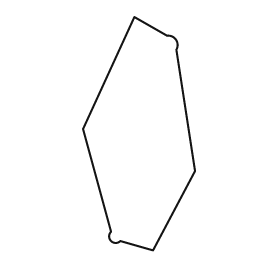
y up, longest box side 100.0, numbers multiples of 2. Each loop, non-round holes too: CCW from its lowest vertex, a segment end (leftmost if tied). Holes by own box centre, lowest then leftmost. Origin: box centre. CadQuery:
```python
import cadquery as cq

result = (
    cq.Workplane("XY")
    .moveTo(6.0, -50.0)
    .lineTo(24.0, -16.0)
    .lineTo(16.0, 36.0)
    .threePointArc((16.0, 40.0), (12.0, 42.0))
    .lineTo(-2.0, 50.0)
    .lineTo(-24.0, 2.0)
    .lineTo(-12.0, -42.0)
    .threePointArc((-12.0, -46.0), (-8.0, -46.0))
    .close()
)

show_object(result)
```